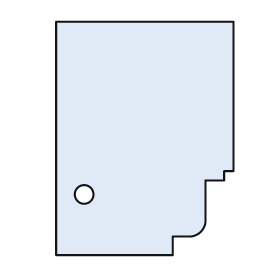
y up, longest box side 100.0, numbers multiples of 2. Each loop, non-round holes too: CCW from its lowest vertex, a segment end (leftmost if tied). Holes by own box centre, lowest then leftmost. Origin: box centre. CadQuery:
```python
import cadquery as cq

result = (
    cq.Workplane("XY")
    .moveTo(-38.0, -50.0)
    .lineTo(12.0, -50.0)
    .lineTo(12.0, -42.0)
    .lineTo(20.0, -42.0)
    .threePointArc((24.0, -40.0), (26.0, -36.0))
    .lineTo(26.0, -18.0)
    .lineTo(34.0, -18.0)
    .lineTo(34.0, -14.0)
    .lineTo(38.0, -14.0)
    .lineTo(38.0, 50.0)
    .lineTo(-38.0, 50.0)
    .close()
    .moveTo(-26.0, -24.0)
    .circle(4.0)
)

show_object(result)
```